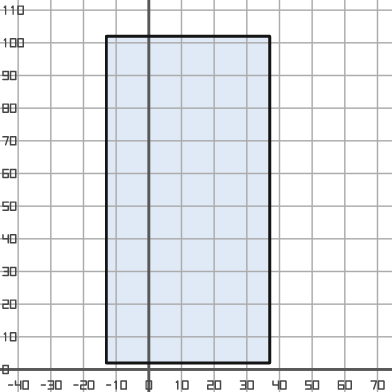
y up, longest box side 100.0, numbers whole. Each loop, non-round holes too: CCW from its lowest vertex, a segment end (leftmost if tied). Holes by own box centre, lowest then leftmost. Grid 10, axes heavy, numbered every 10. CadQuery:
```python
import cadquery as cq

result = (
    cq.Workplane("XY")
    .moveTo(-13.0, 2.0)
    .lineTo(37.0, 2.0)
    .lineTo(37.0, 102.0)
    .lineTo(-13.0, 102.0)
    .close()
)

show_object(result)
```